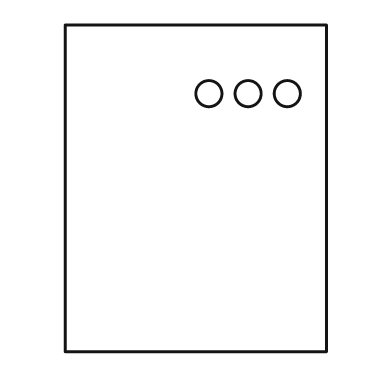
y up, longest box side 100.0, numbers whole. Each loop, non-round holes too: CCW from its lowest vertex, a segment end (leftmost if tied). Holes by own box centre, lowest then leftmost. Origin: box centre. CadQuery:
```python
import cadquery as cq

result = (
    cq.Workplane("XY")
    .moveTo(-40.0, -50.0)
    .lineTo(40.0, -50.0)
    .lineTo(40.0, 50.0)
    .lineTo(-40.0, 50.0)
    .close()
    .moveTo(4.0, 29.0)
    .circle(4.0)
    .moveTo(16.0, 29.0)
    .circle(4.0)
    .moveTo(28.0, 29.0)
    .circle(4.0)
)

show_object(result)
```